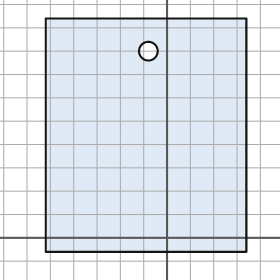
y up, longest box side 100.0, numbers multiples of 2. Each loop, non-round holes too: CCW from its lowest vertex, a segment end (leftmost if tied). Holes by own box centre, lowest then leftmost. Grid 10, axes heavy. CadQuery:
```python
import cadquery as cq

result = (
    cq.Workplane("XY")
    .moveTo(-52.0, -6.0)
    .lineTo(34.0, -6.0)
    .lineTo(34.0, 94.0)
    .lineTo(-52.0, 94.0)
    .close()
    .moveTo(-8.0, 80.0)
    .circle(4.0)
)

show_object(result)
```